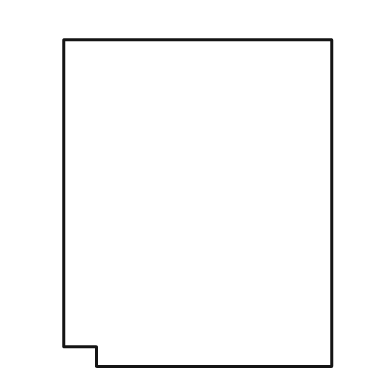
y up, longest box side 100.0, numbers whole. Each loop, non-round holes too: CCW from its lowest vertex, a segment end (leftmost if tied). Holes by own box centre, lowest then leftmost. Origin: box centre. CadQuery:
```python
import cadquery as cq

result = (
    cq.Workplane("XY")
    .moveTo(-31.0, -50.0)
    .lineTo(41.0, -50.0)
    .lineTo(41.0, 50.0)
    .lineTo(-41.0, 50.0)
    .lineTo(-41.0, -44.0)
    .lineTo(-31.0, -44.0)
    .close()
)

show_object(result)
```